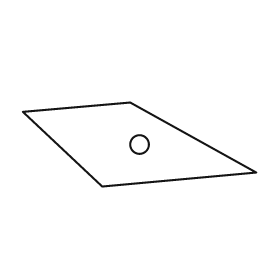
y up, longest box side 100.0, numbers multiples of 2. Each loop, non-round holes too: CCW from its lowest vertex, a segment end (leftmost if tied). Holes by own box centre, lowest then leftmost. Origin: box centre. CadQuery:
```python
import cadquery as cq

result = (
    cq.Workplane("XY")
    .moveTo(-16.0, -18.0)
    .lineTo(50.0, -12.0)
    .lineTo(-4.0, 18.0)
    .lineTo(-50.0, 14.0)
    .close()
    .moveTo(0.0, 0.0)
    .circle(4.0)
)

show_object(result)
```